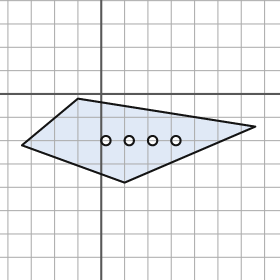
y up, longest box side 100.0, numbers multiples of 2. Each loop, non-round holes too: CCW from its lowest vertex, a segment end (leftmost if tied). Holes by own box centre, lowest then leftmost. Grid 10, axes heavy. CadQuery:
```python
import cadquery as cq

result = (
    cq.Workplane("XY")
    .moveTo(10.0, -38.0)
    .lineTo(66.0, -14.0)
    .lineTo(-10.0, -2.0)
    .lineTo(-34.0, -22.0)
    .close()
    .moveTo(2.0, -20.0)
    .circle(2.0)
    .moveTo(12.0, -20.0)
    .circle(2.0)
    .moveTo(22.0, -20.0)
    .circle(2.0)
    .moveTo(32.0, -20.0)
    .circle(2.0)
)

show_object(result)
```